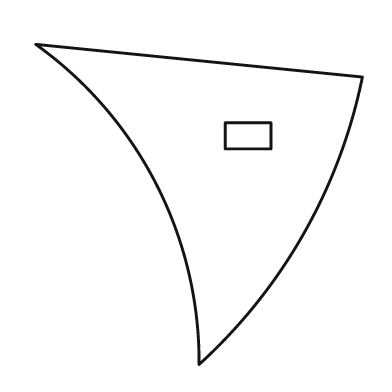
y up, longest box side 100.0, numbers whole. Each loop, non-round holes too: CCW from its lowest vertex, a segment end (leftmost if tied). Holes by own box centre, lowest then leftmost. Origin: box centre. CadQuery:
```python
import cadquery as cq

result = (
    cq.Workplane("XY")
    .moveTo(0.0, -49.0)
    .threePointArc((32.0, -9.0), (50.0, 39.0))
    .lineTo(-50.0, 49.0)
    .threePointArc((-13.0, 6.0), (0.0, -49.0))
    .close()
    .moveTo(8.0, 17.0)
    .lineTo(22.0, 17.0)
    .lineTo(22.0, 25.0)
    .lineTo(8.0, 25.0)
    .close()
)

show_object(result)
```